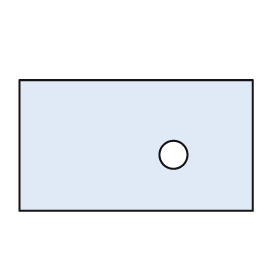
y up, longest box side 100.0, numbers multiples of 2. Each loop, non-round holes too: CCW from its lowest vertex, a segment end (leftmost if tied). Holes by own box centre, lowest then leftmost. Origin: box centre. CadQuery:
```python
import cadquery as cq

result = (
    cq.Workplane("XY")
    .moveTo(-50.0, -28.0)
    .lineTo(50.0, -28.0)
    .lineTo(50.0, 28.0)
    .lineTo(-50.0, 28.0)
    .close()
    .moveTo(16.0, -4.0)
    .circle(6.0)
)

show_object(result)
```